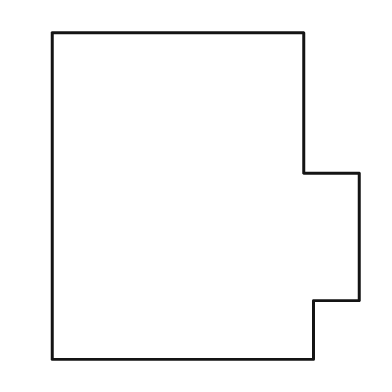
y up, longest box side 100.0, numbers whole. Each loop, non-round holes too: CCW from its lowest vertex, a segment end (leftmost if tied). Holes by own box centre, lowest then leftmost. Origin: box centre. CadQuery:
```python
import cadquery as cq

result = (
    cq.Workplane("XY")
    .moveTo(-47.0, -50.0)
    .lineTo(33.0, -50.0)
    .lineTo(33.0, -32.0)
    .lineTo(47.0, -32.0)
    .lineTo(47.0, 7.0)
    .lineTo(30.0, 7.0)
    .lineTo(30.0, 50.0)
    .lineTo(-47.0, 50.0)
    .close()
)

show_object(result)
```